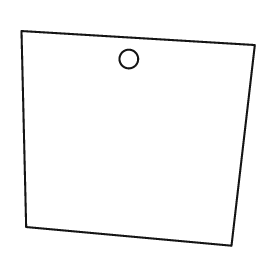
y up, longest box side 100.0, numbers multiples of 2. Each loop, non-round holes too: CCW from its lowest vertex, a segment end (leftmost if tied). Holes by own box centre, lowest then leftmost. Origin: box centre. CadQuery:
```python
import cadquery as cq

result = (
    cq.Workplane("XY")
    .moveTo(40.0, -46.0)
    .lineTo(50.0, 40.0)
    .lineTo(-50.0, 46.0)
    .lineTo(-48.0, -38.0)
    .close()
    .moveTo(-4.0, 34.0)
    .circle(4.0)
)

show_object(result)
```